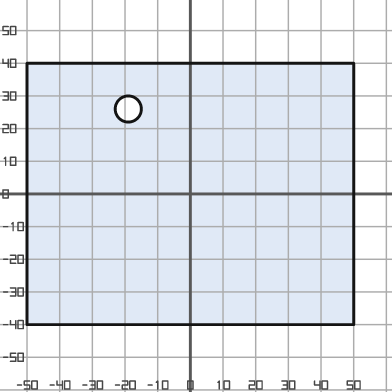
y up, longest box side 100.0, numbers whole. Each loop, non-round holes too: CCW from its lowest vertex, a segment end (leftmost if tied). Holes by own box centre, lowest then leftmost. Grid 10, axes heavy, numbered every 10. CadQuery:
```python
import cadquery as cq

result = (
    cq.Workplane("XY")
    .moveTo(-50.0, -40.0)
    .lineTo(50.0, -40.0)
    .lineTo(50.0, 40.0)
    .lineTo(-50.0, 40.0)
    .close()
    .moveTo(-19.0, 26.0)
    .circle(4.0)
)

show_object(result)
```